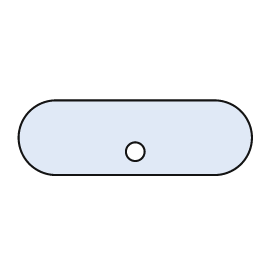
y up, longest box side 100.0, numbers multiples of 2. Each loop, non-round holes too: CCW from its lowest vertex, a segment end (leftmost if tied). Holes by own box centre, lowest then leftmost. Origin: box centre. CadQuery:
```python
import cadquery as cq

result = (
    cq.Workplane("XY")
    .moveTo(-34.0, -16.0)
    .lineTo(34.0, -16.0)
    .threePointArc((50.0, 0.0), (34.0, 16.0))
    .lineTo(-34.0, 16.0)
    .threePointArc((-50.0, 0.0), (-34.0, -16.0))
    .close()
    .moveTo(0.0, -6.0)
    .circle(4.0)
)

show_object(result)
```